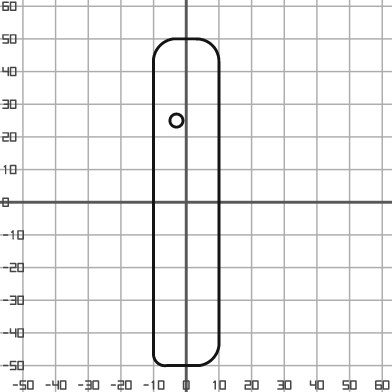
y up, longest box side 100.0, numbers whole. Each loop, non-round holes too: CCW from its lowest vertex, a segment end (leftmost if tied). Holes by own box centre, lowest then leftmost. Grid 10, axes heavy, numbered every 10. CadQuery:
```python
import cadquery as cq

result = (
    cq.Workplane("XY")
    .moveTo(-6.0, -50.0)
    .lineTo(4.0, -50.0)
    .threePointArc((8.0, -48.0), (10.0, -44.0))
    .lineTo(10.0, 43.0)
    .threePointArc((8.0, 48.0), (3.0, 50.0))
    .lineTo(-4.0, 50.0)
    .threePointArc((-8.0, 48.0), (-10.0, 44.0))
    .lineTo(-10.0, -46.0)
    .threePointArc((-9.0, -49.0), (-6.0, -50.0))
    .close()
    .moveTo(-3.0, 25.0)
    .circle(2.0)
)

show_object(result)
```